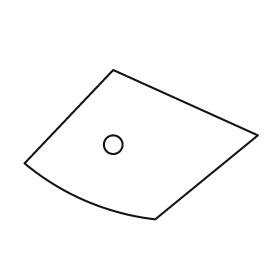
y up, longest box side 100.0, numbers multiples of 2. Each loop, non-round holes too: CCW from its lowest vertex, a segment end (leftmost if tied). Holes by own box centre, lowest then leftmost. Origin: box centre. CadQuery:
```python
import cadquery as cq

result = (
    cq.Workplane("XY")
    .moveTo(6.0, -32.0)
    .lineTo(50.0, 4.0)
    .lineTo(-12.0, 32.0)
    .lineTo(-50.0, -8.0)
    .threePointArc((-24.0, -24.0), (6.0, -32.0))
    .close()
    .moveTo(-12.0, 0.0)
    .circle(4.0)
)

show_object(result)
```